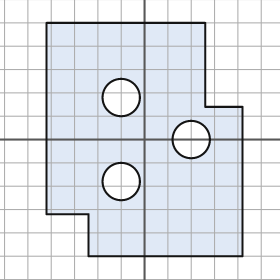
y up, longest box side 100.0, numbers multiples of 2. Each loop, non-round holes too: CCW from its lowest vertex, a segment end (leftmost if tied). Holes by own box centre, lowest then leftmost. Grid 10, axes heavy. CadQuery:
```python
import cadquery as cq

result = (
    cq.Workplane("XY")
    .moveTo(-24.0, -50.0)
    .lineTo(42.0, -50.0)
    .lineTo(42.0, 14.0)
    .lineTo(26.0, 14.0)
    .lineTo(26.0, 50.0)
    .lineTo(-42.0, 50.0)
    .lineTo(-42.0, -32.0)
    .lineTo(-24.0, -32.0)
    .close()
    .moveTo(-10.0, -18.0)
    .circle(8.0)
    .moveTo(20.0, 0.0)
    .circle(8.0)
    .moveTo(-10.0, 18.0)
    .circle(8.0)
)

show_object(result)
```